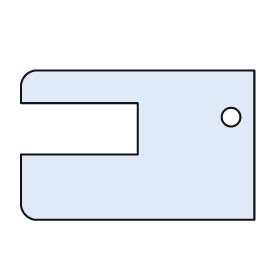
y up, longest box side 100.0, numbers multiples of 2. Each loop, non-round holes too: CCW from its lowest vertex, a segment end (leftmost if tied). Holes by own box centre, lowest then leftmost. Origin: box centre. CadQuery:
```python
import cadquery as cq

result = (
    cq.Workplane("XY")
    .moveTo(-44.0, -32.0)
    .lineTo(50.0, -32.0)
    .lineTo(50.0, 32.0)
    .lineTo(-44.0, 32.0)
    .threePointArc((-48.0, 30.0), (-50.0, 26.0))
    .lineTo(-50.0, 18.0)
    .lineTo(0.0, 18.0)
    .lineTo(0.0, -4.0)
    .lineTo(-50.0, -4.0)
    .lineTo(-50.0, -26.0)
    .threePointArc((-48.0, -30.0), (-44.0, -32.0))
    .close()
    .moveTo(40.0, 12.0)
    .circle(4.0)
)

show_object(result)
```